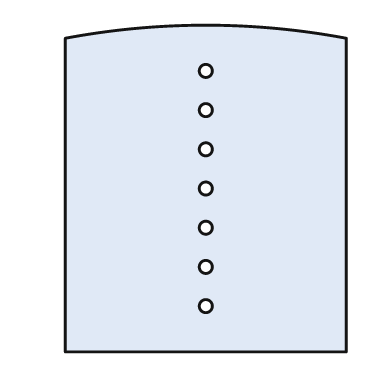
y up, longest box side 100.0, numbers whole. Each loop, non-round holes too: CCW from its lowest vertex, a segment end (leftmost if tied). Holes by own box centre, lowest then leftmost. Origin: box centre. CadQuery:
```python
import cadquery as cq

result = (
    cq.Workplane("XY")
    .moveTo(-43.0, -50.0)
    .lineTo(43.0, -50.0)
    .lineTo(43.0, 46.0)
    .threePointArc((0.0, 50.0), (-43.0, 46.0))
    .close()
    .moveTo(0.0, -36.0)
    .circle(2.0)
    .moveTo(0.0, -24.0)
    .circle(2.0)
    .moveTo(0.0, -12.0)
    .circle(2.0)
    .moveTo(0.0, 0.0)
    .circle(2.0)
    .moveTo(0.0, 12.0)
    .circle(2.0)
    .moveTo(0.0, 24.0)
    .circle(2.0)
    .moveTo(0.0, 36.0)
    .circle(2.0)
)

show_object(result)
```